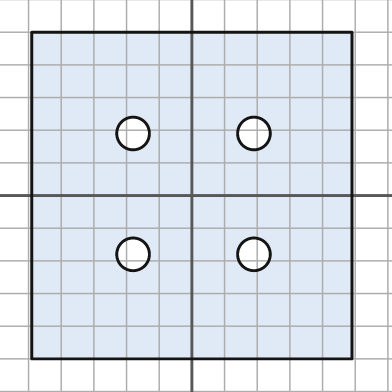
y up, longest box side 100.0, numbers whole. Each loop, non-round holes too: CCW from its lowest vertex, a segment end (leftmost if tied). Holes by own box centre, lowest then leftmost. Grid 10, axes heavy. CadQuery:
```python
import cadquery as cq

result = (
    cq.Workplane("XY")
    .moveTo(-49.0, -50.0)
    .lineTo(49.0, -50.0)
    .lineTo(49.0, 50.0)
    .lineTo(-49.0, 50.0)
    .close()
    .moveTo(-18.0, -18.0)
    .circle(5.0)
    .moveTo(19.0, -18.0)
    .circle(5.0)
    .moveTo(-18.0, 19.0)
    .circle(5.0)
    .moveTo(19.0, 19.0)
    .circle(5.0)
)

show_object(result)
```